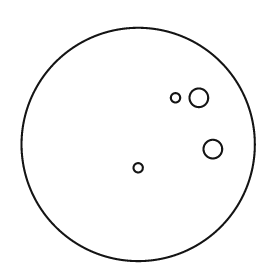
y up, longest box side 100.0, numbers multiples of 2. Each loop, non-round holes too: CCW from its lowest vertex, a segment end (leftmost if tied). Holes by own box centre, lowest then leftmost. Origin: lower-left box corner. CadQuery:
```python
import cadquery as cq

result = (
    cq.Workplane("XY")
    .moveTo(50.0, 50.0)
    .circle(50.0)
    .moveTo(50.0, 40.0)
    .circle(2.0)
    .moveTo(82.0, 48.0)
    .circle(4.0)
    .moveTo(66.0, 70.0)
    .circle(2.0)
    .moveTo(76.0, 70.0)
    .circle(4.0)
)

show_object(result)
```